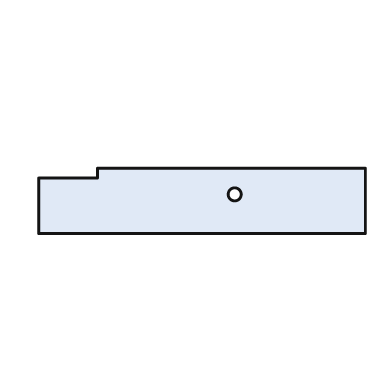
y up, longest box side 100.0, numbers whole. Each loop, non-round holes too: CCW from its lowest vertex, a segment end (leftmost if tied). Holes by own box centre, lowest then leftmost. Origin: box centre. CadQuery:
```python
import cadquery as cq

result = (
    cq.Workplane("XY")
    .moveTo(-50.0, -10.0)
    .lineTo(50.0, -10.0)
    .lineTo(50.0, 10.0)
    .lineTo(-32.0, 10.0)
    .lineTo(-32.0, 7.0)
    .lineTo(-50.0, 7.0)
    .close()
    .moveTo(10.0, 2.0)
    .circle(2.0)
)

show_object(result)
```